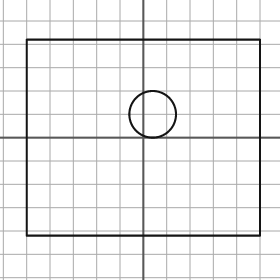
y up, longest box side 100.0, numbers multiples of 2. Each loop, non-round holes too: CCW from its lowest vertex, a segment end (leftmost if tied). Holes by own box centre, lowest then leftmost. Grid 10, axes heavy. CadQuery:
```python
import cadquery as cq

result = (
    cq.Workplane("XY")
    .moveTo(-50.0, -42.0)
    .lineTo(50.0, -42.0)
    .lineTo(50.0, 42.0)
    .lineTo(-50.0, 42.0)
    .close()
    .moveTo(4.0, 10.0)
    .circle(10.0)
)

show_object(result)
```